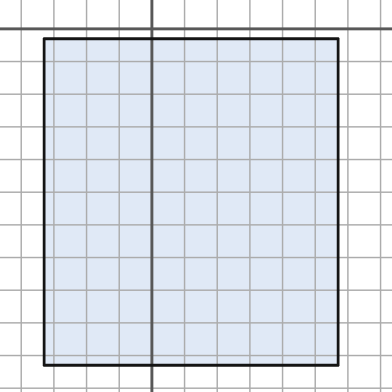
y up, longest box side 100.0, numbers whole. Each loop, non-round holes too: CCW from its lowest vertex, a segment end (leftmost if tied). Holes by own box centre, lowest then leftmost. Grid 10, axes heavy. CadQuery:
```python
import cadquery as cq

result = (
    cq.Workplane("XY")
    .moveTo(-33.0, -103.0)
    .lineTo(57.0, -103.0)
    .lineTo(57.0, -3.0)
    .lineTo(-33.0, -3.0)
    .close()
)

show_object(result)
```